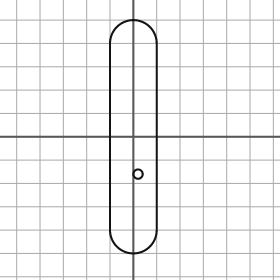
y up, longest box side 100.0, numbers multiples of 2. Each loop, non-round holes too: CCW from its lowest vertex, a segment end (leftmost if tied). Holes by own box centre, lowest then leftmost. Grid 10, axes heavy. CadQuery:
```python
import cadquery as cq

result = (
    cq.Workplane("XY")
    .moveTo(-10.0, -40.0)
    .threePointArc((0.0, -50.0), (10.0, -40.0))
    .lineTo(10.0, 40.0)
    .threePointArc((0.0, 50.0), (-10.0, 40.0))
    .close()
    .moveTo(2.0, -16.0)
    .circle(2.0)
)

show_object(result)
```